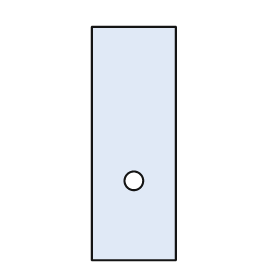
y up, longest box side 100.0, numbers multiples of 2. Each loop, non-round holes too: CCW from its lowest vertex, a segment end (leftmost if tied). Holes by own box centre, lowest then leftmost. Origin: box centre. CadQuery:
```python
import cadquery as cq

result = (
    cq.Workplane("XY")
    .moveTo(-18.0, -50.0)
    .lineTo(18.0, -50.0)
    .lineTo(18.0, 50.0)
    .lineTo(-18.0, 50.0)
    .close()
    .moveTo(0.0, -16.0)
    .circle(4.0)
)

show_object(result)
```